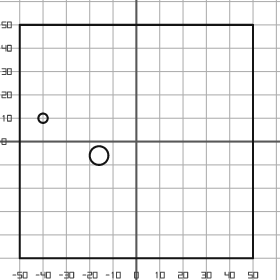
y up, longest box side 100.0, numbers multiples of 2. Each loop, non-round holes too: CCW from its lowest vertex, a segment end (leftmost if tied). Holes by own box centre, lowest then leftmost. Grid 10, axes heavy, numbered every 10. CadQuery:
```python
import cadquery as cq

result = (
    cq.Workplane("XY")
    .moveTo(-50.0, -50.0)
    .lineTo(50.0, -50.0)
    .lineTo(50.0, 50.0)
    .lineTo(-50.0, 50.0)
    .close()
    .moveTo(-16.0, -6.0)
    .circle(4.0)
    .moveTo(-40.0, 10.0)
    .circle(2.0)
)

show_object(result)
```